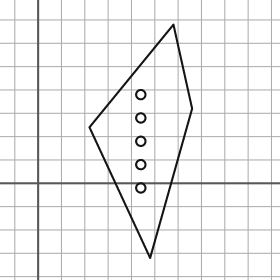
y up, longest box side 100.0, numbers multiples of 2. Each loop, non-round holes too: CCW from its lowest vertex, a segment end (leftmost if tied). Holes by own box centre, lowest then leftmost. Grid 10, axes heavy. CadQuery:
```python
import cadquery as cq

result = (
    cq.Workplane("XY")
    .moveTo(48.0, -32.0)
    .lineTo(66.0, 32.0)
    .lineTo(58.0, 68.0)
    .lineTo(22.0, 24.0)
    .close()
    .moveTo(44.0, -2.0)
    .circle(2.0)
    .moveTo(44.0, 8.0)
    .circle(2.0)
    .moveTo(44.0, 18.0)
    .circle(2.0)
    .moveTo(44.0, 28.0)
    .circle(2.0)
    .moveTo(44.0, 38.0)
    .circle(2.0)
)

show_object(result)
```